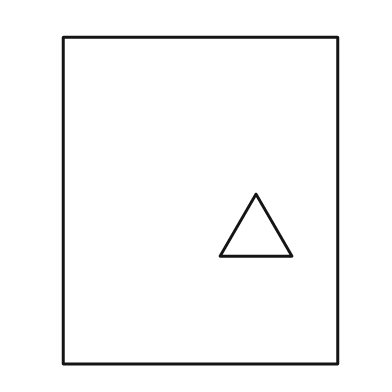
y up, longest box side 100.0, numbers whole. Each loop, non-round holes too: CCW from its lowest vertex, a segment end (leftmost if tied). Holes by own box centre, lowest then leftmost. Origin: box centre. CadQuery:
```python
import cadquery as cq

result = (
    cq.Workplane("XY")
    .moveTo(-42.0, -50.0)
    .lineTo(42.0, -50.0)
    .lineTo(42.0, 50.0)
    .lineTo(-42.0, 50.0)
    .close()
    .moveTo(6.0, -17.0)
    .lineTo(28.0, -17.0)
    .lineTo(17.0, 2.0)
    .close()
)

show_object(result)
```